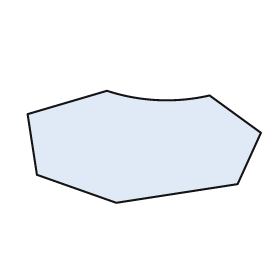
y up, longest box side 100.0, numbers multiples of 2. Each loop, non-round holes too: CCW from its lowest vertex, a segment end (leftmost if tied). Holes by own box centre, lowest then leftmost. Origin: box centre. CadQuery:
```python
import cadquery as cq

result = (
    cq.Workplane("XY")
    .moveTo(-12.0, -24.0)
    .lineTo(40.0, -16.0)
    .lineTo(50.0, 6.0)
    .lineTo(28.0, 22.0)
    .threePointArc((6.0, 20.0), (-16.0, 24.0))
    .lineTo(-50.0, 14.0)
    .lineTo(-46.0, -12.0)
    .close()
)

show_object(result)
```